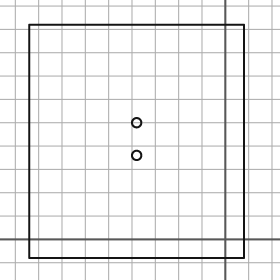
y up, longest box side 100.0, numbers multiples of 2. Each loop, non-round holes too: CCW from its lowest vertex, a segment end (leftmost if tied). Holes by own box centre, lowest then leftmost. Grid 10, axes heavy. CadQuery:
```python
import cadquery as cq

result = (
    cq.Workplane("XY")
    .moveTo(-84.0, -8.0)
    .lineTo(8.0, -8.0)
    .lineTo(8.0, 92.0)
    .lineTo(-84.0, 92.0)
    .close()
    .moveTo(-38.0, 36.0)
    .circle(2.0)
    .moveTo(-38.0, 50.0)
    .circle(2.0)
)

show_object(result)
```